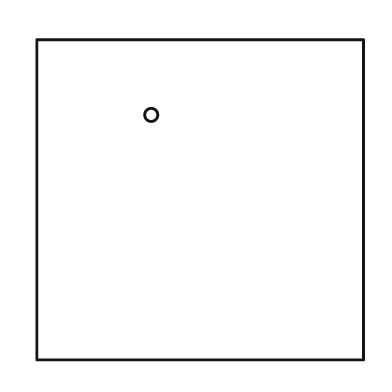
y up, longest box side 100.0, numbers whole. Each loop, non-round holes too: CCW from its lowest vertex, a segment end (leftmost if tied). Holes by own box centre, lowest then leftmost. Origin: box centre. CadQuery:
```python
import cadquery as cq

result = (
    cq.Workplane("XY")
    .moveTo(-50.0, -49.0)
    .lineTo(50.0, -49.0)
    .lineTo(50.0, 49.0)
    .lineTo(-50.0, 49.0)
    .close()
    .moveTo(-15.0, 26.0)
    .circle(2.0)
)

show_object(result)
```